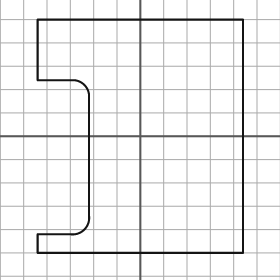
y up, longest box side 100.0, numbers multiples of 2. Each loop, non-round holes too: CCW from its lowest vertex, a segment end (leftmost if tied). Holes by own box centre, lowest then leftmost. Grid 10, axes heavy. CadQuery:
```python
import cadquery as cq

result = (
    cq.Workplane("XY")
    .moveTo(-44.0, -50.0)
    .lineTo(44.0, -50.0)
    .lineTo(44.0, 50.0)
    .lineTo(-44.0, 50.0)
    .lineTo(-44.0, 24.0)
    .lineTo(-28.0, 24.0)
    .threePointArc((-24.0, 22.0), (-22.0, 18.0))
    .lineTo(-22.0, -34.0)
    .threePointArc((-24.0, -40.0), (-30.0, -42.0))
    .lineTo(-44.0, -42.0)
    .close()
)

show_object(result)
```